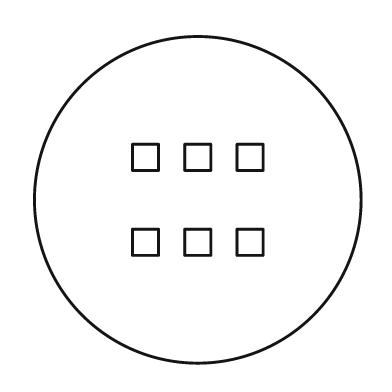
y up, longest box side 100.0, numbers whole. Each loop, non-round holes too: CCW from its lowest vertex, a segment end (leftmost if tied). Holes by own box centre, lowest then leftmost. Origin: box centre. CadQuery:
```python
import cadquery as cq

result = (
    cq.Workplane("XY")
    .moveTo(0.0, 0.0)
    .circle(50.0)
    .moveTo(-20.0, -17.0)
    .lineTo(-12.0, -17.0)
    .lineTo(-12.0, -9.0)
    .lineTo(-20.0, -9.0)
    .close()
    .moveTo(-4.0, -17.0)
    .lineTo(4.0, -17.0)
    .lineTo(4.0, -9.0)
    .lineTo(-4.0, -9.0)
    .close()
    .moveTo(12.0, -17.0)
    .lineTo(20.0, -17.0)
    .lineTo(20.0, -9.0)
    .lineTo(12.0, -9.0)
    .close()
    .moveTo(-20.0, 9.0)
    .lineTo(-12.0, 9.0)
    .lineTo(-12.0, 17.0)
    .lineTo(-20.0, 17.0)
    .close()
    .moveTo(-4.0, 9.0)
    .lineTo(4.0, 9.0)
    .lineTo(4.0, 17.0)
    .lineTo(-4.0, 17.0)
    .close()
    .moveTo(12.0, 9.0)
    .lineTo(20.0, 9.0)
    .lineTo(20.0, 17.0)
    .lineTo(12.0, 17.0)
    .close()
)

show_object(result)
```